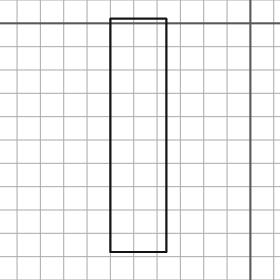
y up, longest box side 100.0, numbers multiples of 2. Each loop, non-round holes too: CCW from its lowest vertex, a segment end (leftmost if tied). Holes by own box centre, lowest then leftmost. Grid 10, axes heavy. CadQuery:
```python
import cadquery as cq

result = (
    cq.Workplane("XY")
    .moveTo(-60.0, -98.0)
    .lineTo(-36.0, -98.0)
    .lineTo(-36.0, 2.0)
    .lineTo(-60.0, 2.0)
    .close()
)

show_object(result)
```